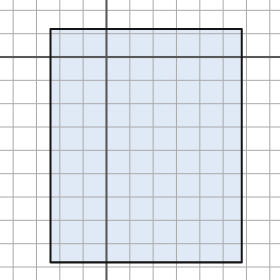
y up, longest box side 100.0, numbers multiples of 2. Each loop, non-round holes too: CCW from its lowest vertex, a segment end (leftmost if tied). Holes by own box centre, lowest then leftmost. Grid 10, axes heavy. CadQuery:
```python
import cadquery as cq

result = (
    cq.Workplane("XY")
    .moveTo(-24.0, -88.0)
    .lineTo(58.0, -88.0)
    .lineTo(58.0, 12.0)
    .lineTo(-24.0, 12.0)
    .close()
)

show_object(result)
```